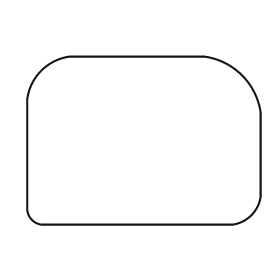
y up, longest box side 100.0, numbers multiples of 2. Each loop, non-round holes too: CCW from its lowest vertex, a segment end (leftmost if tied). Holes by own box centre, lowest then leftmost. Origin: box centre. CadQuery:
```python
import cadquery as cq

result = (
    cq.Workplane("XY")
    .moveTo(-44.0, -36.0)
    .lineTo(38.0, -36.0)
    .threePointArc((46.0, -32.0), (50.0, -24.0))
    .lineTo(50.0, 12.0)
    .threePointArc((42.0, 28.0), (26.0, 36.0))
    .lineTo(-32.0, 36.0)
    .threePointArc((-44.0, 30.0), (-50.0, 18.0))
    .lineTo(-50.0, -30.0)
    .threePointArc((-48.0, -34.0), (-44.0, -36.0))
    .close()
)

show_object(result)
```